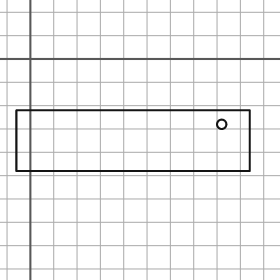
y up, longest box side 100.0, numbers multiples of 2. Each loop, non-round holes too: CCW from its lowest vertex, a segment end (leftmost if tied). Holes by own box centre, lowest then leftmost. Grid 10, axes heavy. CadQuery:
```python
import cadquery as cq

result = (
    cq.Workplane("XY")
    .moveTo(-6.0, -48.0)
    .lineTo(94.0, -48.0)
    .lineTo(94.0, -22.0)
    .lineTo(-6.0, -22.0)
    .close()
    .moveTo(82.0, -28.0)
    .circle(2.0)
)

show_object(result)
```